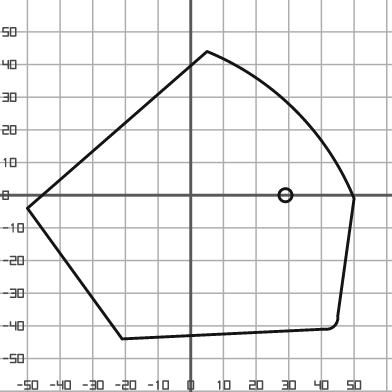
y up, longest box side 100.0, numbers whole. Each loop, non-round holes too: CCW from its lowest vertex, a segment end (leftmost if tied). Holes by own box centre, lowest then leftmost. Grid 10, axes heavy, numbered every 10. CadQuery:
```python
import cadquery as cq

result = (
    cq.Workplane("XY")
    .moveTo(-21.0, -44.0)
    .lineTo(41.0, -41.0)
    .threePointArc((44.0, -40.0), (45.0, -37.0))
    .lineTo(50.0, -1.0)
    .threePointArc((32.0, 26.0), (5.0, 44.0))
    .lineTo(-50.0, -4.0)
    .close()
    .moveTo(29.0, 0.0)
    .circle(2.0)
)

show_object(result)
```